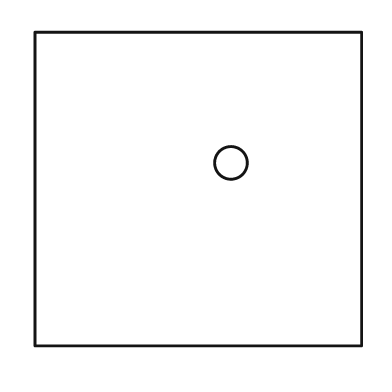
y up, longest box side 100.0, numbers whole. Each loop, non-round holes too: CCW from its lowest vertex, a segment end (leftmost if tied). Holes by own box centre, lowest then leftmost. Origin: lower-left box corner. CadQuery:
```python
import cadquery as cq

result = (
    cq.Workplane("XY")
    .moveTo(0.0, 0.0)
    .lineTo(100.0, 0.0)
    .lineTo(100.0, 96.0)
    .lineTo(0.0, 96.0)
    .close()
    .moveTo(60.0, 56.0)
    .circle(5.0)
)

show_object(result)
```